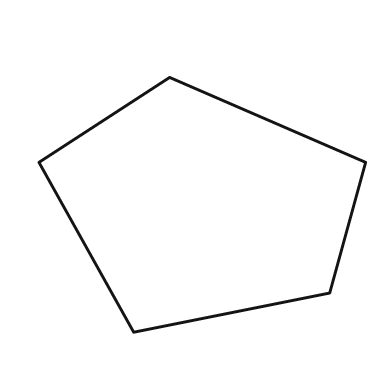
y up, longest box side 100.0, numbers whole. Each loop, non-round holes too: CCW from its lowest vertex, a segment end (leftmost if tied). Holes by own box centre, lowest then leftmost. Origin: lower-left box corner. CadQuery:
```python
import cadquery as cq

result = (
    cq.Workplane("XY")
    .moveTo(29.0, 0.0)
    .lineTo(89.0, 12.0)
    .lineTo(100.0, 52.0)
    .lineTo(40.0, 78.0)
    .lineTo(0.0, 52.0)
    .close()
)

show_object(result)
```